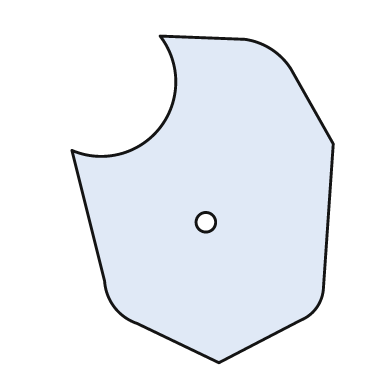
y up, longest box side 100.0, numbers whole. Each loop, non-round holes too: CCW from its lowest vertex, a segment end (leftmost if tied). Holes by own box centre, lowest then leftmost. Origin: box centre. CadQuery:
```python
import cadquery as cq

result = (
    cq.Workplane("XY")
    .moveTo(5.0, -50.0)
    .lineTo(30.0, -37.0)
    .threePointArc((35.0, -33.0), (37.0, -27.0))
    .lineTo(40.0, 17.0)
    .lineTo(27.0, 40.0)
    .threePointArc((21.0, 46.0), (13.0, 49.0))
    .lineTo(-13.0, 50.0)
    .threePointArc((-13.0, 22.0), (-40.0, 15.0))
    .lineTo(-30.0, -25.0)
    .threePointArc((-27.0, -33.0), (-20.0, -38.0))
    .close()
    .moveTo(1.0, -7.0)
    .circle(3.0)
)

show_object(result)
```